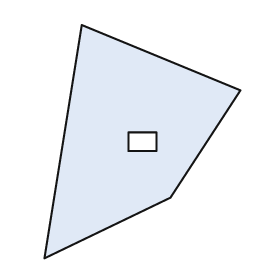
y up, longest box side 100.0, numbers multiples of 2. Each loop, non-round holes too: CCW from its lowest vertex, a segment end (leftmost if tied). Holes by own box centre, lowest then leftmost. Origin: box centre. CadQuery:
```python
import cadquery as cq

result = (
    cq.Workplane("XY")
    .moveTo(-42.0, -50.0)
    .lineTo(12.0, -24.0)
    .lineTo(42.0, 22.0)
    .lineTo(-26.0, 50.0)
    .close()
    .moveTo(-6.0, -4.0)
    .lineTo(6.0, -4.0)
    .lineTo(6.0, 4.0)
    .lineTo(-6.0, 4.0)
    .close()
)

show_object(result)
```